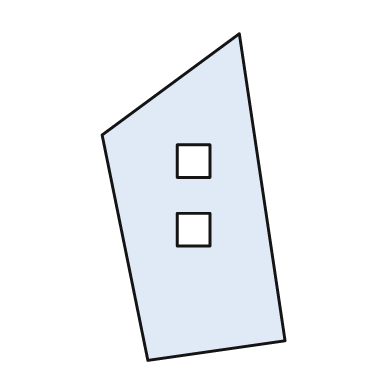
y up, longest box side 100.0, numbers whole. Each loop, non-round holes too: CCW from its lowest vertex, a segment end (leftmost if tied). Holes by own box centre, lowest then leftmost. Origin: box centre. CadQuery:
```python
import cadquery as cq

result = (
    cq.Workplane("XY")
    .moveTo(-14.0, -50.0)
    .lineTo(28.0, -44.0)
    .lineTo(14.0, 50.0)
    .lineTo(-28.0, 19.0)
    .close()
    .moveTo(-5.0, -15.0)
    .lineTo(5.0, -15.0)
    .lineTo(5.0, -5.0)
    .lineTo(-5.0, -5.0)
    .close()
    .moveTo(-5.0, 6.0)
    .lineTo(5.0, 6.0)
    .lineTo(5.0, 16.0)
    .lineTo(-5.0, 16.0)
    .close()
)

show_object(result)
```